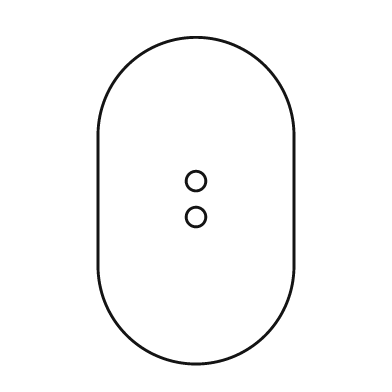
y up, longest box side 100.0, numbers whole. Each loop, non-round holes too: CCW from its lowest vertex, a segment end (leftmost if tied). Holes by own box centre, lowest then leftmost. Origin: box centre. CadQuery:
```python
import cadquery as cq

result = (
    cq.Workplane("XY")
    .moveTo(-30.0, -20.0)
    .threePointArc((0.0, -50.0), (30.0, -20.0))
    .lineTo(30.0, 20.0)
    .threePointArc((0.0, 50.0), (-30.0, 20.0))
    .close()
    .moveTo(0.0, -5.0)
    .circle(3.0)
    .moveTo(0.0, 6.0)
    .circle(3.0)
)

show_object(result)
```